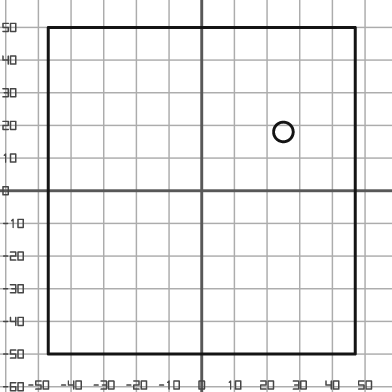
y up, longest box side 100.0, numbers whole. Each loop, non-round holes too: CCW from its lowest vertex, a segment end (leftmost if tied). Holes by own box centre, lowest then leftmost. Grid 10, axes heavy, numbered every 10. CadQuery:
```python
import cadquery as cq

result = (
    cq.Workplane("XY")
    .moveTo(-47.0, -50.0)
    .lineTo(47.0, -50.0)
    .lineTo(47.0, 50.0)
    .lineTo(-47.0, 50.0)
    .close()
    .moveTo(25.0, 18.0)
    .circle(3.0)
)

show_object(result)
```